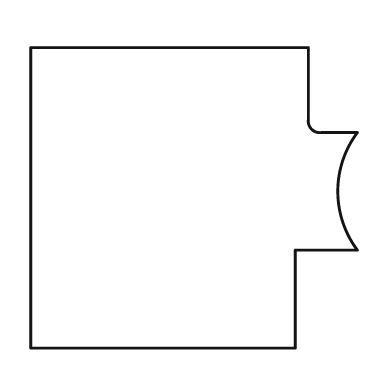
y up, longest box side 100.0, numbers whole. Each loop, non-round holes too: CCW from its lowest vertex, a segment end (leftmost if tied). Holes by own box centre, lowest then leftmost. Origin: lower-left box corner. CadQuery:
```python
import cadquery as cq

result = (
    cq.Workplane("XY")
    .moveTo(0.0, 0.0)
    .lineTo(81.0, 0.0)
    .lineTo(81.0, 30.0)
    .lineTo(100.0, 30.0)
    .threePointArc((94.0, 48.0), (100.0, 66.0))
    .lineTo(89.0, 66.0)
    .threePointArc((86.0, 67.0), (85.0, 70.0))
    .lineTo(85.0, 92.0)
    .lineTo(0.0, 92.0)
    .close()
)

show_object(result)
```